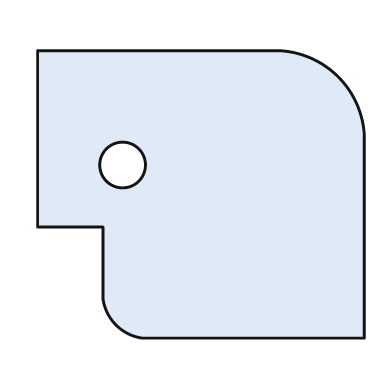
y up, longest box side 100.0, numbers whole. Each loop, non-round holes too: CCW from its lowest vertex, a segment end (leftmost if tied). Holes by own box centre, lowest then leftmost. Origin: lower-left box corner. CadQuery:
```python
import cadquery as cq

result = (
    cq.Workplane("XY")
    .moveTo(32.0, 0.0)
    .lineTo(100.0, 0.0)
    .lineTo(100.0, 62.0)
    .threePointArc((92.0, 80.0), (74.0, 88.0))
    .lineTo(0.0, 88.0)
    .lineTo(0.0, 34.0)
    .lineTo(20.0, 34.0)
    .lineTo(20.0, 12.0)
    .threePointArc((24.0, 4.0), (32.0, 0.0))
    .close()
    .moveTo(26.0, 53.0)
    .circle(7.0)
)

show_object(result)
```